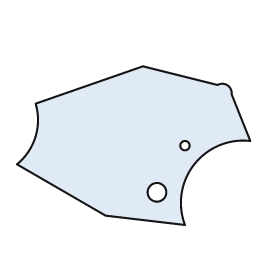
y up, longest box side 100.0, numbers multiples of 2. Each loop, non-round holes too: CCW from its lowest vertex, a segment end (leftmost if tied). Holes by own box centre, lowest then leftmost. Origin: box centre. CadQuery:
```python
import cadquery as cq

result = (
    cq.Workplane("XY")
    .moveTo(22.0, -34.0)
    .threePointArc((26.0, -8.0), (50.0, 2.0))
    .lineTo(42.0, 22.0)
    .threePointArc((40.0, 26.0), (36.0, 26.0))
    .lineTo(4.0, 34.0)
    .lineTo(-42.0, 18.0)
    .threePointArc((-42.0, 4.0), (-50.0, -8.0))
    .lineTo(-12.0, -30.0)
    .close()
    .moveTo(10.0, -20.0)
    .circle(4.0)
    .moveTo(22.0, 0.0)
    .circle(2.0)
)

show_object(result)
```